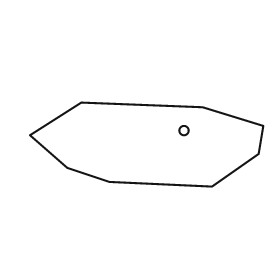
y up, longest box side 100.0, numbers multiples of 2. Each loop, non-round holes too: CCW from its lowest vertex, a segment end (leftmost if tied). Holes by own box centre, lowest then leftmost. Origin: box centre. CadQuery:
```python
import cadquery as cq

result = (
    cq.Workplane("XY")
    .moveTo(28.0, -18.0)
    .lineTo(48.0, -4.0)
    .lineTo(50.0, 8.0)
    .lineTo(24.0, 16.0)
    .lineTo(-28.0, 18.0)
    .lineTo(-50.0, 4.0)
    .lineTo(-34.0, -10.0)
    .lineTo(-16.0, -16.0)
    .close()
    .moveTo(16.0, 6.0)
    .circle(2.0)
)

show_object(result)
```